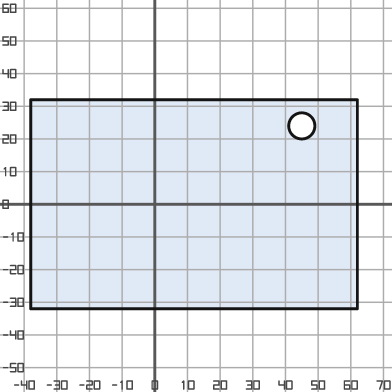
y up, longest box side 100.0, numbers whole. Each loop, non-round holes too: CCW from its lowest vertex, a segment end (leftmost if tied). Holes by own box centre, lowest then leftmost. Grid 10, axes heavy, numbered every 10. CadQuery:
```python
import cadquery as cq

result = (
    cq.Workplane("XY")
    .moveTo(-38.0, -32.0)
    .lineTo(62.0, -32.0)
    .lineTo(62.0, 32.0)
    .lineTo(-38.0, 32.0)
    .close()
    .moveTo(45.0, 24.0)
    .circle(4.0)
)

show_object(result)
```